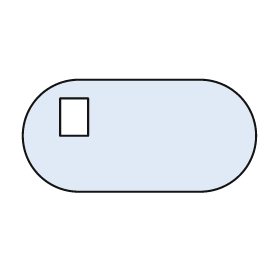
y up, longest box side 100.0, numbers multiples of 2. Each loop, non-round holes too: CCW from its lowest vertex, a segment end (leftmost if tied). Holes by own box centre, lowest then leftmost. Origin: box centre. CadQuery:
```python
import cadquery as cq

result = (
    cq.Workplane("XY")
    .moveTo(-26.0, -24.0)
    .lineTo(26.0, -24.0)
    .threePointArc((50.0, 0.0), (26.0, 24.0))
    .lineTo(-26.0, 24.0)
    .threePointArc((-50.0, 0.0), (-26.0, -24.0))
    .close()
    .moveTo(-34.0, 0.0)
    .lineTo(-22.0, 0.0)
    .lineTo(-22.0, 16.0)
    .lineTo(-34.0, 16.0)
    .close()
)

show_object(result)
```